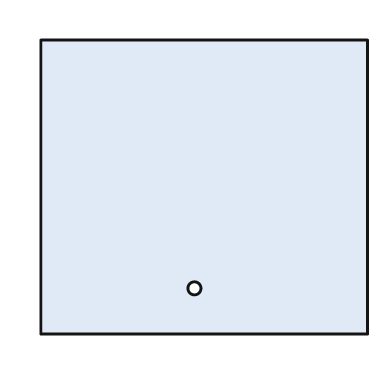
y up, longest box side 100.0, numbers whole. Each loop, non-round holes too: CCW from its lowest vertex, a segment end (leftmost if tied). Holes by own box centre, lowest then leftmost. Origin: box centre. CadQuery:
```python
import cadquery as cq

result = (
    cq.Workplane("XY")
    .moveTo(-50.0, -45.0)
    .lineTo(50.0, -45.0)
    .lineTo(50.0, 45.0)
    .lineTo(-50.0, 45.0)
    .close()
    .moveTo(-3.0, -31.0)
    .circle(2.0)
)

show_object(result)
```